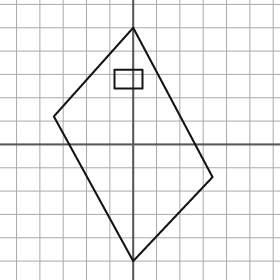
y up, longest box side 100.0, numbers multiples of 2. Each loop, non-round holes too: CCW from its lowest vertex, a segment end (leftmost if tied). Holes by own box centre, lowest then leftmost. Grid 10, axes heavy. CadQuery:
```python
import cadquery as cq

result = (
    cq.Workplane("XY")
    .moveTo(0.0, -50.0)
    .lineTo(34.0, -14.0)
    .lineTo(0.0, 50.0)
    .lineTo(-34.0, 12.0)
    .close()
    .moveTo(-8.0, 24.0)
    .lineTo(4.0, 24.0)
    .lineTo(4.0, 32.0)
    .lineTo(-8.0, 32.0)
    .close()
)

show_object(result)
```